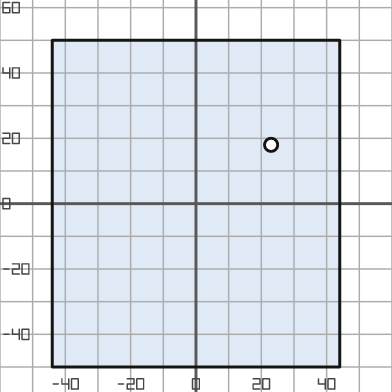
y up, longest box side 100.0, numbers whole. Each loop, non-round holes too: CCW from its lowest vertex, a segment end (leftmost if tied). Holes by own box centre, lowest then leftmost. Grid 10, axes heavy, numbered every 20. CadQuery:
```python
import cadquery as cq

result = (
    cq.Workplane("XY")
    .moveTo(-44.0, -50.0)
    .lineTo(44.0, -50.0)
    .lineTo(44.0, 50.0)
    .lineTo(-44.0, 50.0)
    .close()
    .moveTo(23.0, 18.0)
    .circle(2.0)
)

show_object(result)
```